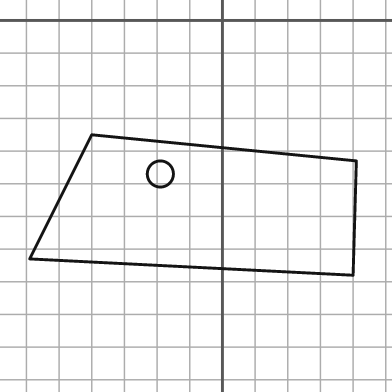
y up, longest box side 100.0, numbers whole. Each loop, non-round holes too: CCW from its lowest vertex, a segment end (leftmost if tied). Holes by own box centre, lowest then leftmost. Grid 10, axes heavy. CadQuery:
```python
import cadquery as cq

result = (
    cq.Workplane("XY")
    .moveTo(40.0, -78.0)
    .lineTo(41.0, -43.0)
    .lineTo(-40.0, -35.0)
    .lineTo(-59.0, -73.0)
    .close()
    .moveTo(-19.0, -47.0)
    .circle(4.0)
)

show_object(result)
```